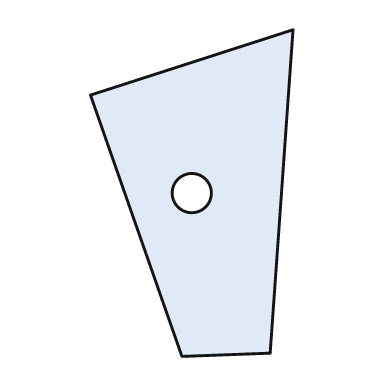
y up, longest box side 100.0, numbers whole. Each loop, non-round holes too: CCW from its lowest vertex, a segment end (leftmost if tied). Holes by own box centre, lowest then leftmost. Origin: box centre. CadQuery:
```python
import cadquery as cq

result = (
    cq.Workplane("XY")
    .moveTo(-3.0, -50.0)
    .lineTo(24.0, -49.0)
    .lineTo(31.0, 50.0)
    .lineTo(-31.0, 30.0)
    .close()
    .moveTo(0.0, 0.0)
    .circle(6.0)
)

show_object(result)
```